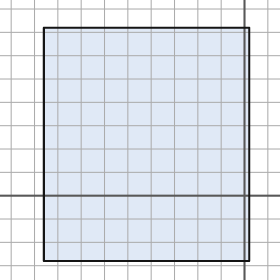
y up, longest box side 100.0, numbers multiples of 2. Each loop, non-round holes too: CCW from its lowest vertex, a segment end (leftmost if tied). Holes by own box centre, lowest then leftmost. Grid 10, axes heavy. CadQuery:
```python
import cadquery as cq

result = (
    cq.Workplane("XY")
    .moveTo(-86.0, -28.0)
    .lineTo(2.0, -28.0)
    .lineTo(2.0, 72.0)
    .lineTo(-86.0, 72.0)
    .close()
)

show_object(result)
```